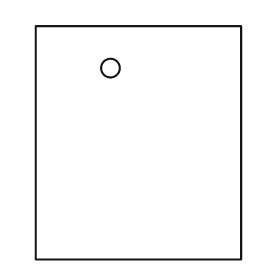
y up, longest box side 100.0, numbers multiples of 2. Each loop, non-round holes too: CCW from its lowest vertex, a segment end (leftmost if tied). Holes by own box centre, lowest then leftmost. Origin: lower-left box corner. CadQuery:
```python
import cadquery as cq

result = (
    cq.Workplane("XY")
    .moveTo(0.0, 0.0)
    .lineTo(88.0, 0.0)
    .lineTo(88.0, 100.0)
    .lineTo(0.0, 100.0)
    .close()
    .moveTo(32.0, 82.0)
    .circle(4.0)
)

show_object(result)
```